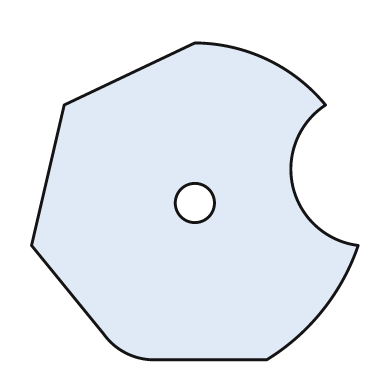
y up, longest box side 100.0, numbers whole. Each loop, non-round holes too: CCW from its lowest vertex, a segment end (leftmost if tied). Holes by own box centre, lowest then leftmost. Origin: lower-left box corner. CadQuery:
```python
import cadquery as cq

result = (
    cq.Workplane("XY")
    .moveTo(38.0, 0.0)
    .lineTo(72.0, 0.0)
    .threePointArc((89.0, 15.0), (100.0, 35.0))
    .threePointArc((80.0, 53.0), (90.0, 78.0))
    .threePointArc((72.0, 92.0), (50.0, 97.0))
    .lineTo(10.0, 78.0)
    .lineTo(0.0, 35.0)
    .lineTo(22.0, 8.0)
    .threePointArc((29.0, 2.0), (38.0, 0.0))
    .close()
    .moveTo(50.0, 48.0)
    .circle(6.0)
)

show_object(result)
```